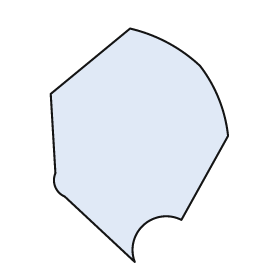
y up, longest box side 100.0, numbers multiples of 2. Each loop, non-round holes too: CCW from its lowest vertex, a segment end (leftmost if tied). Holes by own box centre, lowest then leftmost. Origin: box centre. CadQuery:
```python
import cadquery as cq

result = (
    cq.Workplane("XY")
    .moveTo(-2.0, -50.0)
    .threePointArc((2.0, -34.0), (18.0, -32.0))
    .lineTo(38.0, 4.0)
    .threePointArc((34.0, 20.0), (26.0, 34.0))
    .threePointArc((12.0, 44.0), (-4.0, 50.0))
    .lineTo(-38.0, 22.0)
    .lineTo(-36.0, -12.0)
    .threePointArc((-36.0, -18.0), (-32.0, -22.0))
    .close()
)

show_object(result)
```